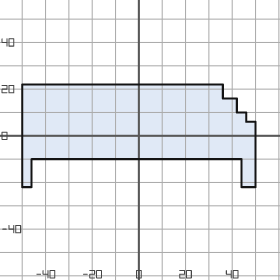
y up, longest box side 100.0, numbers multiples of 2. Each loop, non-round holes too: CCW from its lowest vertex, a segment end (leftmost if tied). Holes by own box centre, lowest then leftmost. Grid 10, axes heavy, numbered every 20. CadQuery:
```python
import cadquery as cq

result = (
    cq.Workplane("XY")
    .moveTo(-50.0, -22.0)
    .lineTo(-46.0, -22.0)
    .lineTo(-46.0, -10.0)
    .lineTo(44.0, -10.0)
    .lineTo(44.0, -22.0)
    .lineTo(50.0, -22.0)
    .lineTo(50.0, 6.0)
    .lineTo(46.0, 6.0)
    .lineTo(46.0, 10.0)
    .lineTo(42.0, 10.0)
    .lineTo(42.0, 16.0)
    .lineTo(36.0, 16.0)
    .lineTo(36.0, 22.0)
    .lineTo(-50.0, 22.0)
    .close()
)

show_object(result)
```